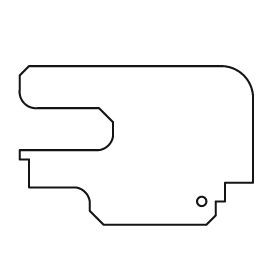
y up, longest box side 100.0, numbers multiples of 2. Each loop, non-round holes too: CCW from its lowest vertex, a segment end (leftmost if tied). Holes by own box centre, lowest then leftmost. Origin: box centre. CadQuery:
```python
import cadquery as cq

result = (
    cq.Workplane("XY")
    .moveTo(-14.0, -34.0)
    .lineTo(30.0, -34.0)
    .lineTo(34.0, -30.0)
    .lineTo(34.0, -24.0)
    .lineTo(38.0, -24.0)
    .lineTo(38.0, -16.0)
    .lineTo(50.0, -16.0)
    .lineTo(50.0, 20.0)
    .threePointArc((46.0, 30.0), (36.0, 34.0))
    .lineTo(-46.0, 34.0)
    .lineTo(-50.0, 30.0)
    .lineTo(-50.0, 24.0)
    .threePointArc((-48.0, 18.0), (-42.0, 16.0))
    .lineTo(-16.0, 16.0)
    .lineTo(-10.0, 10.0)
    .lineTo(-10.0, 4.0)
    .threePointArc((-12.0, 0.0), (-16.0, -2.0))
    .lineTo(-50.0, -2.0)
    .lineTo(-50.0, -6.0)
    .lineTo(-46.0, -6.0)
    .lineTo(-46.0, -18.0)
    .lineTo(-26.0, -18.0)
    .threePointArc((-22.0, -20.0), (-20.0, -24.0))
    .lineTo(-20.0, -28.0)
    .close()
    .moveTo(28.0, -24.0)
    .circle(2.0)
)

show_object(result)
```